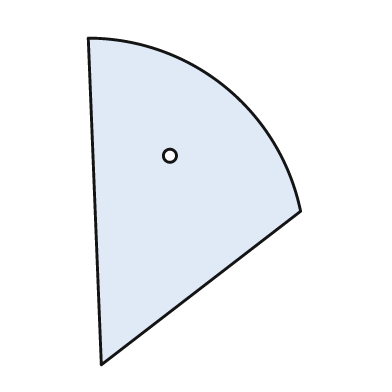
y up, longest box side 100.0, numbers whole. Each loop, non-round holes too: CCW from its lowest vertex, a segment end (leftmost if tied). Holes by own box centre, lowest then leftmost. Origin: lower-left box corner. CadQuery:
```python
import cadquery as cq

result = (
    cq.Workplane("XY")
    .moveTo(4.0, 0.0)
    .lineTo(65.0, 47.0)
    .threePointArc((42.0, 85.0), (0.0, 100.0))
    .close()
    .moveTo(25.0, 64.0)
    .circle(2.0)
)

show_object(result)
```